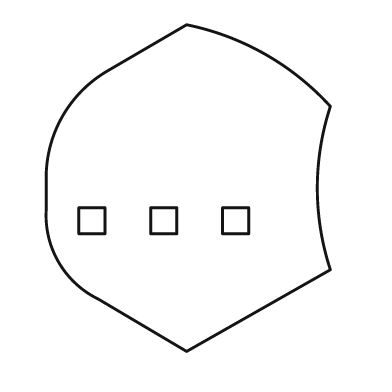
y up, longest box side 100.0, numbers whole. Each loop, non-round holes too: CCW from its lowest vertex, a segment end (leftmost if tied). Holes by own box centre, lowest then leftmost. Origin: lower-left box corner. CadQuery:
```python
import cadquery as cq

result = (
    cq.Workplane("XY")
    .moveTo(43.0, 0.0)
    .lineTo(87.0, 25.0)
    .threePointArc((83.0, 50.0), (87.0, 75.0))
    .threePointArc((67.0, 91.0), (43.0, 100.0))
    .lineTo(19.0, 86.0)
    .threePointArc((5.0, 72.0), (0.0, 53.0))
    .lineTo(0.0, 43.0)
    .threePointArc((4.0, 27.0), (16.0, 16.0))
    .close()
    .moveTo(10.0, 36.0)
    .lineTo(18.0, 36.0)
    .lineTo(18.0, 44.0)
    .lineTo(10.0, 44.0)
    .close()
    .moveTo(32.0, 36.0)
    .lineTo(40.0, 36.0)
    .lineTo(40.0, 44.0)
    .lineTo(32.0, 44.0)
    .close()
    .moveTo(54.0, 36.0)
    .lineTo(62.0, 36.0)
    .lineTo(62.0, 44.0)
    .lineTo(54.0, 44.0)
    .close()
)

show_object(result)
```